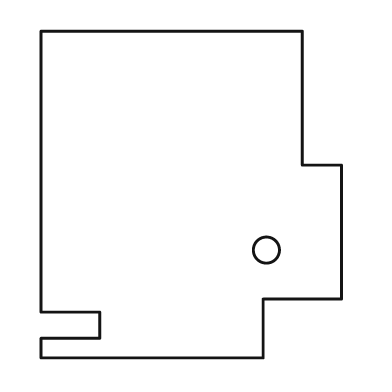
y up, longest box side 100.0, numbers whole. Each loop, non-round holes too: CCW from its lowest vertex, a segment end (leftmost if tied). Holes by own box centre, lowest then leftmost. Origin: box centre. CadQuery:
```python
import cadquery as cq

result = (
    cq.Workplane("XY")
    .moveTo(-46.0, -50.0)
    .lineTo(22.0, -50.0)
    .lineTo(22.0, -32.0)
    .lineTo(46.0, -32.0)
    .lineTo(46.0, 9.0)
    .lineTo(34.0, 9.0)
    .lineTo(34.0, 50.0)
    .lineTo(-46.0, 50.0)
    .lineTo(-46.0, -36.0)
    .lineTo(-28.0, -36.0)
    .lineTo(-28.0, -44.0)
    .lineTo(-46.0, -44.0)
    .close()
    .moveTo(23.0, -17.0)
    .circle(4.0)
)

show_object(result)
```